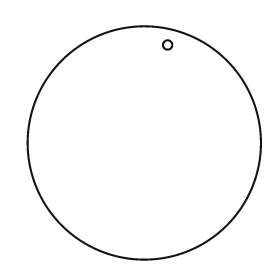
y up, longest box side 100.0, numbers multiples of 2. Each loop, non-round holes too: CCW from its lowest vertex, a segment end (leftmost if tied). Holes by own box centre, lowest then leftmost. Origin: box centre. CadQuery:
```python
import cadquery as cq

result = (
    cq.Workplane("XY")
    .moveTo(0.0, 0.0)
    .circle(50.0)
    .moveTo(10.0, 42.0)
    .circle(2.0)
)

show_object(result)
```